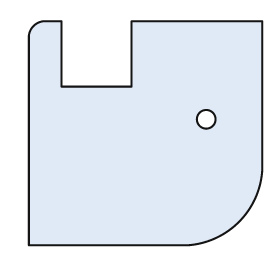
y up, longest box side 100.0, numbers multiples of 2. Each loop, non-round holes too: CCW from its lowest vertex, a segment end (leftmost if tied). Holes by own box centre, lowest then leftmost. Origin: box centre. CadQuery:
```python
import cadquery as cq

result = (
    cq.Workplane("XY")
    .moveTo(-50.0, -48.0)
    .lineTo(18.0, -48.0)
    .threePointArc((40.0, -38.0), (50.0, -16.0))
    .lineTo(50.0, 48.0)
    .lineTo(-6.0, 48.0)
    .lineTo(-6.0, 20.0)
    .lineTo(-36.0, 20.0)
    .lineTo(-36.0, 48.0)
    .lineTo(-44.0, 48.0)
    .threePointArc((-48.0, 46.0), (-50.0, 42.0))
    .close()
    .moveTo(26.0, 6.0)
    .circle(4.0)
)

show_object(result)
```